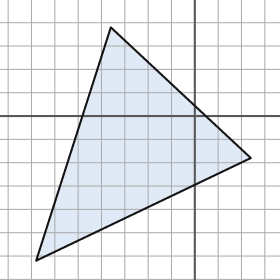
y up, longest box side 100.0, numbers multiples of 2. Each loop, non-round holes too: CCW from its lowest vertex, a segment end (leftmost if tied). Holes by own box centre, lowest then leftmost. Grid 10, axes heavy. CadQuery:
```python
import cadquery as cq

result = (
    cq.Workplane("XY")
    .moveTo(-68.0, -62.0)
    .lineTo(24.0, -18.0)
    .lineTo(-36.0, 38.0)
    .close()
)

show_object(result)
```